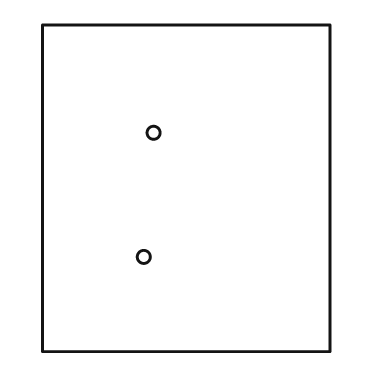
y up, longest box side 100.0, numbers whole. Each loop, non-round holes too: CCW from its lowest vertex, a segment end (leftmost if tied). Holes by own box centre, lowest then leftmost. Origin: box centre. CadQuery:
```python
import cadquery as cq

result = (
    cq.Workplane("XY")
    .moveTo(-44.0, -50.0)
    .lineTo(44.0, -50.0)
    .lineTo(44.0, 50.0)
    .lineTo(-44.0, 50.0)
    .close()
    .moveTo(-13.0, -21.0)
    .circle(2.0)
    .moveTo(-10.0, 17.0)
    .circle(2.0)
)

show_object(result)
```